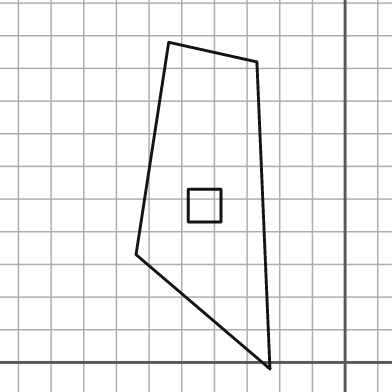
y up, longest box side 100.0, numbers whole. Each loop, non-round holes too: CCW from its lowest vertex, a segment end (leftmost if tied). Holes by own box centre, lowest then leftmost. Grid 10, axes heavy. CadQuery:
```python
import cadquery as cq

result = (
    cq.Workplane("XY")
    .moveTo(-23.0, -2.0)
    .lineTo(-27.0, 92.0)
    .lineTo(-54.0, 98.0)
    .lineTo(-64.0, 33.0)
    .close()
    .moveTo(-48.0, 43.0)
    .lineTo(-38.0, 43.0)
    .lineTo(-38.0, 53.0)
    .lineTo(-48.0, 53.0)
    .close()
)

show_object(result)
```